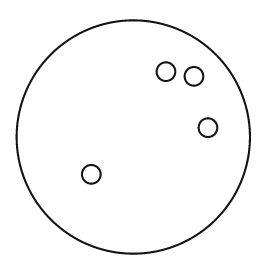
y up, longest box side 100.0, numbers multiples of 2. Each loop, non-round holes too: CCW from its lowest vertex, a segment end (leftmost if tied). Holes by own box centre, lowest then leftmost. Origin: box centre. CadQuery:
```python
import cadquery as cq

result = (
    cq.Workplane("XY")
    .moveTo(0.0, 0.0)
    .circle(50.0)
    .moveTo(-18.0, -16.0)
    .circle(4.0)
    .moveTo(32.0, 4.0)
    .circle(4.0)
    .moveTo(26.0, 26.0)
    .circle(4.0)
    .moveTo(14.0, 28.0)
    .circle(4.0)
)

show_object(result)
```